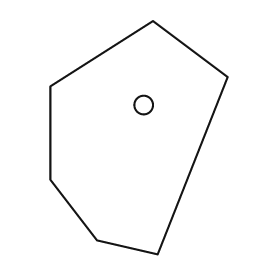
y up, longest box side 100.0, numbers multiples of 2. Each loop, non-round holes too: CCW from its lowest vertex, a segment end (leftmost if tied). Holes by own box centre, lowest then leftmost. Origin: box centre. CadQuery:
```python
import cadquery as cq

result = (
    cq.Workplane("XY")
    .moveTo(8.0, -50.0)
    .lineTo(38.0, 26.0)
    .lineTo(6.0, 50.0)
    .lineTo(-38.0, 22.0)
    .lineTo(-38.0, -18.0)
    .lineTo(-18.0, -44.0)
    .close()
    .moveTo(2.0, 14.0)
    .circle(4.0)
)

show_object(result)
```